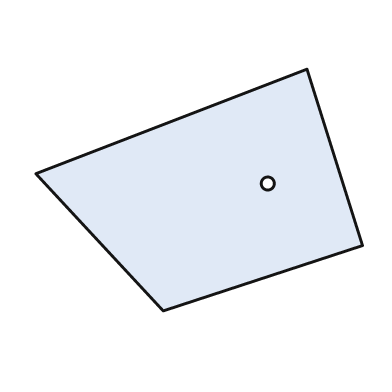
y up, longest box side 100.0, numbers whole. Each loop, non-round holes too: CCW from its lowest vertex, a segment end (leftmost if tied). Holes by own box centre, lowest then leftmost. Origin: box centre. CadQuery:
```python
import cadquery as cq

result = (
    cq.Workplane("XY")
    .moveTo(-11.0, -37.0)
    .lineTo(50.0, -17.0)
    .lineTo(33.0, 37.0)
    .lineTo(-50.0, 5.0)
    .close()
    .moveTo(21.0, 2.0)
    .circle(2.0)
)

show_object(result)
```